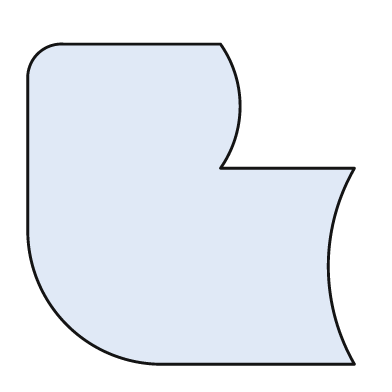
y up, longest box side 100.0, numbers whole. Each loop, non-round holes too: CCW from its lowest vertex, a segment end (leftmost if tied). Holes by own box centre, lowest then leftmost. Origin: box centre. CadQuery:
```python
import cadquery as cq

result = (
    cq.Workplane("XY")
    .moveTo(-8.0, -49.0)
    .lineTo(50.0, -49.0)
    .threePointArc((42.0, -19.0), (50.0, 11.0))
    .lineTo(9.0, 11.0)
    .threePointArc((15.0, 30.0), (9.0, 49.0))
    .lineTo(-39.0, 49.0)
    .threePointArc((-47.0, 46.0), (-50.0, 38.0))
    .lineTo(-50.0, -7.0)
    .threePointArc((-38.0, -37.0), (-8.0, -49.0))
    .close()
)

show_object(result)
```